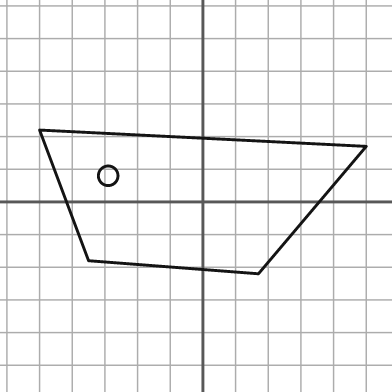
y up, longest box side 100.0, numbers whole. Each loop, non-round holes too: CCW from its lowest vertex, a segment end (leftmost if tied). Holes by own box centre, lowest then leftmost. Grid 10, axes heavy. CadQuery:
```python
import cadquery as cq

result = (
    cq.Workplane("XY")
    .moveTo(17.0, -22.0)
    .lineTo(50.0, 17.0)
    .lineTo(-50.0, 22.0)
    .lineTo(-35.0, -18.0)
    .close()
    .moveTo(-29.0, 8.0)
    .circle(3.0)
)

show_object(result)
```